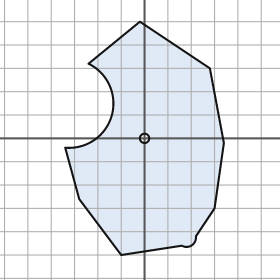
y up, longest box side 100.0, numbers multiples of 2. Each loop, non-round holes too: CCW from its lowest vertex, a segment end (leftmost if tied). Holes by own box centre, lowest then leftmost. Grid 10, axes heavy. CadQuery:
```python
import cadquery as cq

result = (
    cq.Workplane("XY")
    .moveTo(-10.0, -50.0)
    .lineTo(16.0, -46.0)
    .threePointArc((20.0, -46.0), (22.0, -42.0))
    .lineTo(30.0, -30.0)
    .lineTo(34.0, -2.0)
    .lineTo(28.0, 30.0)
    .lineTo(-2.0, 50.0)
    .lineTo(-24.0, 32.0)
    .threePointArc((-14.0, 10.0), (-34.0, -4.0))
    .lineTo(-28.0, -26.0)
    .close()
    .moveTo(0.0, 0.0)
    .circle(2.0)
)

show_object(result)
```